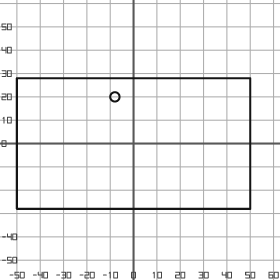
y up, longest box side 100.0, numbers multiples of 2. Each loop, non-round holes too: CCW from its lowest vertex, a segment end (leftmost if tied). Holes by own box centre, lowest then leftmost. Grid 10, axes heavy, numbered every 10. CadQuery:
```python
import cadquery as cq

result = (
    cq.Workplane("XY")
    .moveTo(-50.0, -28.0)
    .lineTo(50.0, -28.0)
    .lineTo(50.0, 28.0)
    .lineTo(-50.0, 28.0)
    .close()
    .moveTo(-8.0, 20.0)
    .circle(2.0)
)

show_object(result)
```